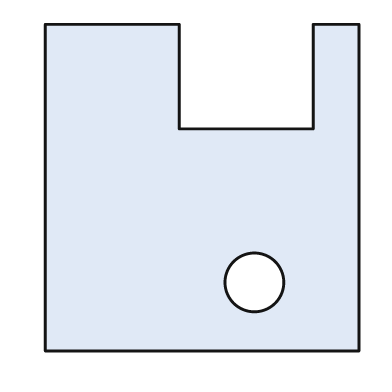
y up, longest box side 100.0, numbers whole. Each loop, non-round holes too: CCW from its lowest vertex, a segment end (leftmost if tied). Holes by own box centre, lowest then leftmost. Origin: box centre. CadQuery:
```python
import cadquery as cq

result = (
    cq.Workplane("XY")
    .moveTo(-48.0, -50.0)
    .lineTo(48.0, -50.0)
    .lineTo(48.0, 50.0)
    .lineTo(34.0, 50.0)
    .lineTo(34.0, 18.0)
    .lineTo(-7.0, 18.0)
    .lineTo(-7.0, 50.0)
    .lineTo(-48.0, 50.0)
    .close()
    .moveTo(16.0, -29.0)
    .circle(9.0)
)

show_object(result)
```